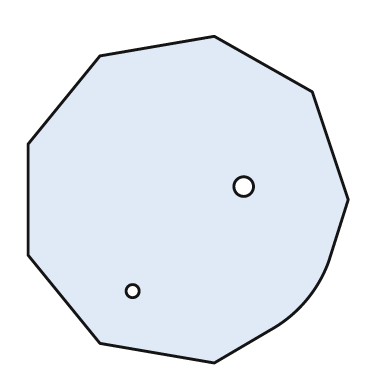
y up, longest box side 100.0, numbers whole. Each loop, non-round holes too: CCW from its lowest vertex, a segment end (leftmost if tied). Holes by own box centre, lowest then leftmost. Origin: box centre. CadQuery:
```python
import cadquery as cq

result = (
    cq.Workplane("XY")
    .moveTo(8.0, -50.0)
    .lineTo(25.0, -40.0)
    .threePointArc((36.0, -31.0), (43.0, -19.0))
    .lineTo(49.0, 0.0)
    .lineTo(38.0, 33.0)
    .lineTo(8.0, 50.0)
    .lineTo(-27.0, 44.0)
    .lineTo(-49.0, 17.0)
    .lineTo(-49.0, -17.0)
    .lineTo(-27.0, -44.0)
    .close()
    .moveTo(-17.0, -28.0)
    .circle(2.0)
    .moveTo(17.0, 4.0)
    .circle(3.0)
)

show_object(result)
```